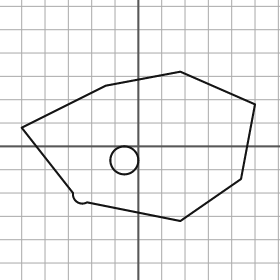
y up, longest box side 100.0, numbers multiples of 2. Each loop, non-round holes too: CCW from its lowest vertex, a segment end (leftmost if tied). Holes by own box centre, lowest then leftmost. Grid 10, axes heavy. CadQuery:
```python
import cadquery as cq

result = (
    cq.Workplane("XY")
    .moveTo(18.0, -32.0)
    .lineTo(44.0, -14.0)
    .lineTo(50.0, 18.0)
    .lineTo(18.0, 32.0)
    .lineTo(-14.0, 26.0)
    .lineTo(-50.0, 8.0)
    .lineTo(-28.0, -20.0)
    .threePointArc((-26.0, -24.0), (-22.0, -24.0))
    .close()
    .moveTo(-6.0, -6.0)
    .circle(6.0)
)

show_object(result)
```